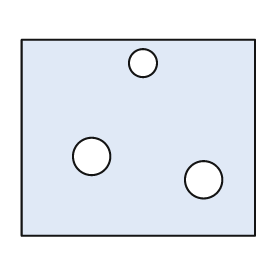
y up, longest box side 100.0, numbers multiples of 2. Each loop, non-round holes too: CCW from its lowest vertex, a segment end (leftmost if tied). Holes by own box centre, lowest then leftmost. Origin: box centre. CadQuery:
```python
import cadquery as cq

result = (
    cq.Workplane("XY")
    .moveTo(-50.0, -42.0)
    .lineTo(50.0, -42.0)
    .lineTo(50.0, 42.0)
    .lineTo(-50.0, 42.0)
    .close()
    .moveTo(28.0, -18.0)
    .circle(8.0)
    .moveTo(-20.0, -8.0)
    .circle(8.0)
    .moveTo(2.0, 32.0)
    .circle(6.0)
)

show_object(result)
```